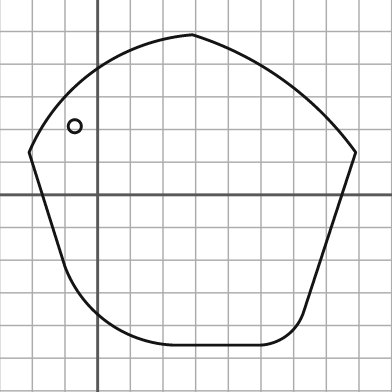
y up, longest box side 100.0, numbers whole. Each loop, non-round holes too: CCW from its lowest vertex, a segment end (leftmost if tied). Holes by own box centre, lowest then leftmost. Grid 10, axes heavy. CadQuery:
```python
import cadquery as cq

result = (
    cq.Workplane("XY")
    .moveTo(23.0, -46.0)
    .lineTo(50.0, -46.0)
    .threePointArc((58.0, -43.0), (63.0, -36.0))
    .lineTo(79.0, 13.0)
    .threePointArc((57.0, 35.0), (29.0, 49.0))
    .threePointArc((-1.0, 38.0), (-21.0, 13.0))
    .lineTo(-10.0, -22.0)
    .threePointArc((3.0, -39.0), (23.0, -46.0))
    .close()
    .moveTo(-7.0, 21.0)
    .circle(2.0)
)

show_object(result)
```